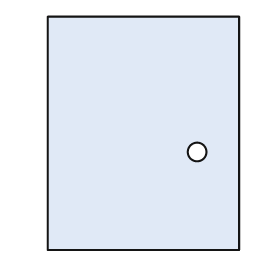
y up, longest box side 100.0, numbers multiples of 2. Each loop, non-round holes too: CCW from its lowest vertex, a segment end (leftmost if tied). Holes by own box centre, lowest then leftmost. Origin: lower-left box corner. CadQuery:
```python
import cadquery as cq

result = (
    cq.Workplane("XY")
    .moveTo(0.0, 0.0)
    .lineTo(82.0, 0.0)
    .lineTo(82.0, 100.0)
    .lineTo(0.0, 100.0)
    .close()
    .moveTo(64.0, 42.0)
    .circle(4.0)
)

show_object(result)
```